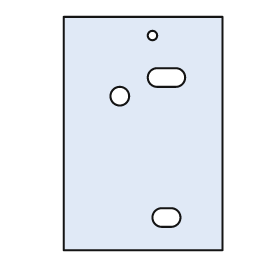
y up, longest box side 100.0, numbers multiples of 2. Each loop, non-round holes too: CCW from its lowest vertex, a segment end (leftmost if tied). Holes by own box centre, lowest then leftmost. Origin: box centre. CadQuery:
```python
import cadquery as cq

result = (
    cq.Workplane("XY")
    .moveTo(-34.0, -50.0)
    .lineTo(34.0, -50.0)
    .lineTo(34.0, 50.0)
    .lineTo(-34.0, 50.0)
    .close()
    .moveTo(8.0, -40.0)
    .lineTo(12.0, -40.0)
    .threePointArc((16.0, -36.0), (12.0, -32.0))
    .lineTo(8.0, -32.0)
    .threePointArc((4.0, -36.0), (8.0, -40.0))
    .close()
    .moveTo(-10.0, 16.0)
    .circle(4.0)
    .moveTo(6.0, 20.0)
    .lineTo(14.0, 20.0)
    .threePointArc((18.0, 24.0), (14.0, 28.0))
    .lineTo(6.0, 28.0)
    .threePointArc((2.0, 24.0), (6.0, 20.0))
    .close()
    .moveTo(4.0, 42.0)
    .circle(2.0)
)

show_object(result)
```